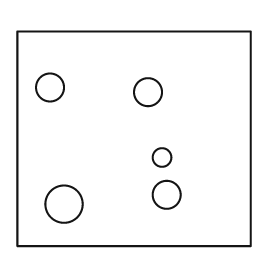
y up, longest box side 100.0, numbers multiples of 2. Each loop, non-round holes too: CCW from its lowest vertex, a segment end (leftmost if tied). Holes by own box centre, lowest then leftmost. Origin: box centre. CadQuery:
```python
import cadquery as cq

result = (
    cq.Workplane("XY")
    .moveTo(-50.0, -46.0)
    .lineTo(50.0, -46.0)
    .lineTo(50.0, 46.0)
    .lineTo(-50.0, 46.0)
    .close()
    .moveTo(-30.0, -28.0)
    .circle(8.0)
    .moveTo(14.0, -24.0)
    .circle(6.0)
    .moveTo(12.0, -8.0)
    .circle(4.0)
    .moveTo(6.0, 20.0)
    .circle(6.0)
    .moveTo(-36.0, 22.0)
    .circle(6.0)
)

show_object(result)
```